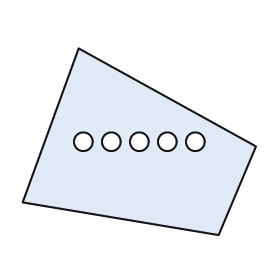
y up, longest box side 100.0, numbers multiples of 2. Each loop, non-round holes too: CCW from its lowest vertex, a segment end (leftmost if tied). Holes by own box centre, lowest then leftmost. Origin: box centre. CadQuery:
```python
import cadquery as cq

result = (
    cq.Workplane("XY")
    .moveTo(34.0, -40.0)
    .lineTo(50.0, -2.0)
    .lineTo(-26.0, 40.0)
    .lineTo(-50.0, -26.0)
    .close()
    .moveTo(-24.0, 0.0)
    .circle(4.0)
    .moveTo(-12.0, 0.0)
    .circle(4.0)
    .moveTo(0.0, 0.0)
    .circle(4.0)
    .moveTo(12.0, 0.0)
    .circle(4.0)
    .moveTo(24.0, 0.0)
    .circle(4.0)
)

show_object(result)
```